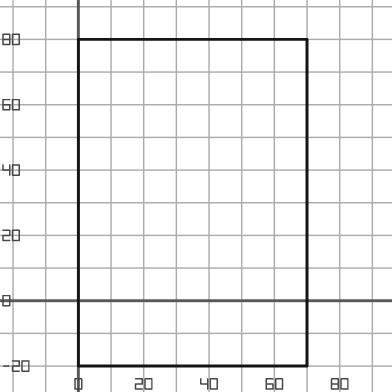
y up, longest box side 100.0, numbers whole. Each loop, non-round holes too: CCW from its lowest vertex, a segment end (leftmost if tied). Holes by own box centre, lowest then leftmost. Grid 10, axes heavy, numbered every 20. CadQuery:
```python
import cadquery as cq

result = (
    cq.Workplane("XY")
    .moveTo(0.0, -20.0)
    .lineTo(70.0, -20.0)
    .lineTo(70.0, 80.0)
    .lineTo(0.0, 80.0)
    .close()
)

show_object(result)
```